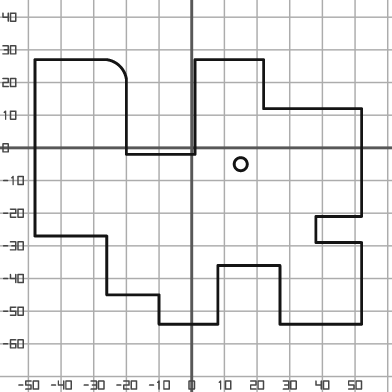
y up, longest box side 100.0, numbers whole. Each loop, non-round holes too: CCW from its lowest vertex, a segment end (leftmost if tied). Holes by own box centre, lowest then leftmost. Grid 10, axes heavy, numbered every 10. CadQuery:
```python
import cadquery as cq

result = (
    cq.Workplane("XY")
    .moveTo(-10.0, -54.0)
    .lineTo(8.0, -54.0)
    .lineTo(8.0, -36.0)
    .lineTo(27.0, -36.0)
    .lineTo(27.0, -54.0)
    .lineTo(52.0, -54.0)
    .lineTo(52.0, -29.0)
    .lineTo(38.0, -29.0)
    .lineTo(38.0, -21.0)
    .lineTo(52.0, -21.0)
    .lineTo(52.0, 12.0)
    .lineTo(22.0, 12.0)
    .lineTo(22.0, 27.0)
    .lineTo(1.0, 27.0)
    .lineTo(1.0, -2.0)
    .lineTo(-20.0, -2.0)
    .lineTo(-20.0, 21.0)
    .threePointArc((-22.0, 25.0), (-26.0, 27.0))
    .lineTo(-48.0, 27.0)
    .lineTo(-48.0, -27.0)
    .lineTo(-26.0, -27.0)
    .lineTo(-26.0, -45.0)
    .lineTo(-10.0, -45.0)
    .close()
    .moveTo(15.0, -5.0)
    .circle(2.0)
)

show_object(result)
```